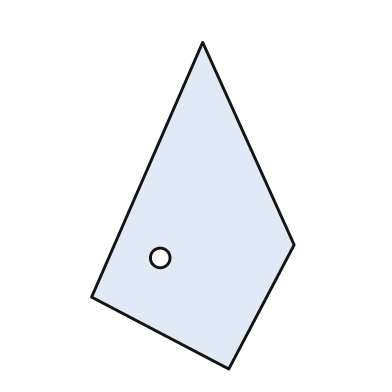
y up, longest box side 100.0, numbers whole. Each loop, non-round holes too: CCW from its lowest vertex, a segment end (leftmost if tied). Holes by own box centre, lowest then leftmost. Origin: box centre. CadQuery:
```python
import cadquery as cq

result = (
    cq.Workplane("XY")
    .moveTo(11.0, -50.0)
    .lineTo(31.0, -12.0)
    .lineTo(3.0, 50.0)
    .lineTo(-31.0, -28.0)
    .close()
    .moveTo(-10.0, -16.0)
    .circle(3.0)
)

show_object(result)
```